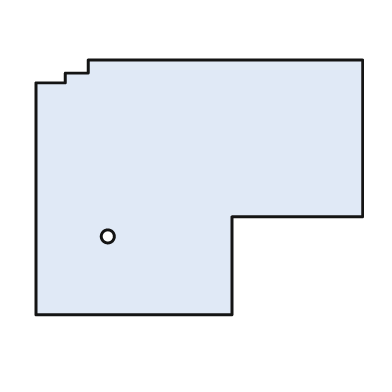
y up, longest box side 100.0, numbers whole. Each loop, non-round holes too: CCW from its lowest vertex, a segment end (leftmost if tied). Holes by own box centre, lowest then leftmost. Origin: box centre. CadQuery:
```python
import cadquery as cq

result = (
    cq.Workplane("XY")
    .moveTo(-50.0, -39.0)
    .lineTo(10.0, -39.0)
    .lineTo(10.0, -9.0)
    .lineTo(50.0, -9.0)
    .lineTo(50.0, 39.0)
    .lineTo(-34.0, 39.0)
    .lineTo(-34.0, 35.0)
    .lineTo(-41.0, 35.0)
    .lineTo(-41.0, 32.0)
    .lineTo(-50.0, 32.0)
    .close()
    .moveTo(-28.0, -15.0)
    .circle(2.0)
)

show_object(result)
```